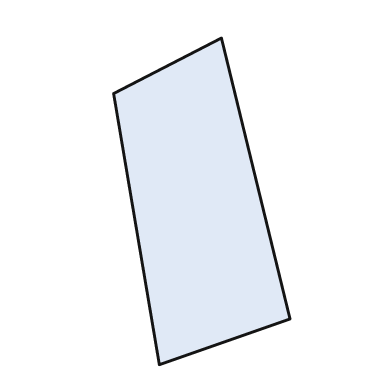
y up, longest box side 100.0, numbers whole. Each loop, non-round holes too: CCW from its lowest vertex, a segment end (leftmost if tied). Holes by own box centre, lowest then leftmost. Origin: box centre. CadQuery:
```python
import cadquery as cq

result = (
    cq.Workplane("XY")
    .moveTo(-13.0, -50.0)
    .lineTo(27.0, -36.0)
    .lineTo(6.0, 50.0)
    .lineTo(-27.0, 33.0)
    .close()
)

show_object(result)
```